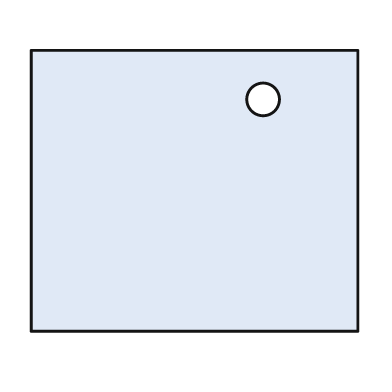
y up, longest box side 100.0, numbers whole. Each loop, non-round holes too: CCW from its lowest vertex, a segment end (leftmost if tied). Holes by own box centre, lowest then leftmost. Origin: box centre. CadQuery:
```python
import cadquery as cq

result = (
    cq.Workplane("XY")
    .moveTo(-50.0, -43.0)
    .lineTo(50.0, -43.0)
    .lineTo(50.0, 43.0)
    .lineTo(-50.0, 43.0)
    .close()
    .moveTo(21.0, 28.0)
    .circle(5.0)
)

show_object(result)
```